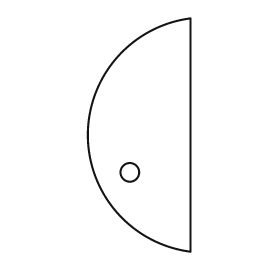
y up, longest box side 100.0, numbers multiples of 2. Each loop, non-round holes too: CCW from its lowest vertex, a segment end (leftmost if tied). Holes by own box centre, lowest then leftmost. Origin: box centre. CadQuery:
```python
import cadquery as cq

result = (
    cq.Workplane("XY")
    .moveTo(22.0, -50.0)
    .lineTo(22.0, 50.0)
    .threePointArc((-22.0, 0.0), (22.0, -50.0))
    .close()
    .moveTo(-4.0, -16.0)
    .circle(4.0)
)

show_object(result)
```